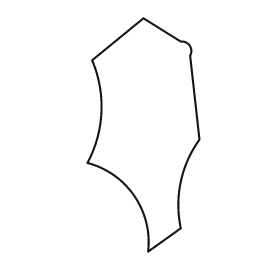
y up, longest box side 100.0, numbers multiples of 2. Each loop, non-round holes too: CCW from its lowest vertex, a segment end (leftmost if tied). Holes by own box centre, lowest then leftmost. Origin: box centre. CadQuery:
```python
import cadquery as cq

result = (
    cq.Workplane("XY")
    .moveTo(2.0, -50.0)
    .lineTo(16.0, -40.0)
    .threePointArc((16.0, -20.0), (24.0, -2.0))
    .lineTo(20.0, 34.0)
    .threePointArc((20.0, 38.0), (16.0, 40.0))
    .lineTo(0.0, 50.0)
    .lineTo(-22.0, 32.0)
    .threePointArc((-18.0, 10.0), (-24.0, -12.0))
    .threePointArc((-4.0, -26.0), (2.0, -50.0))
    .close()
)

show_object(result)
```